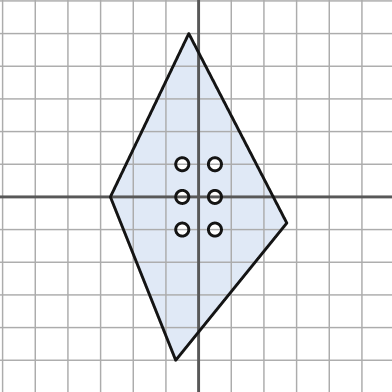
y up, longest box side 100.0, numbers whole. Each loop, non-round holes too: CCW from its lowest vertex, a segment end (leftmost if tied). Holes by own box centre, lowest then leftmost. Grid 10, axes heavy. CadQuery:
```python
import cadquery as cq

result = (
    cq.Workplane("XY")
    .moveTo(-7.0, -50.0)
    .lineTo(27.0, -8.0)
    .lineTo(-3.0, 50.0)
    .lineTo(-27.0, 0.0)
    .close()
    .moveTo(-5.0, -10.0)
    .circle(2.0)
    .moveTo(5.0, -10.0)
    .circle(2.0)
    .moveTo(-5.0, 0.0)
    .circle(2.0)
    .moveTo(5.0, 0.0)
    .circle(2.0)
    .moveTo(-5.0, 10.0)
    .circle(2.0)
    .moveTo(5.0, 10.0)
    .circle(2.0)
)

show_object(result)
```